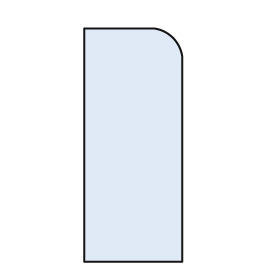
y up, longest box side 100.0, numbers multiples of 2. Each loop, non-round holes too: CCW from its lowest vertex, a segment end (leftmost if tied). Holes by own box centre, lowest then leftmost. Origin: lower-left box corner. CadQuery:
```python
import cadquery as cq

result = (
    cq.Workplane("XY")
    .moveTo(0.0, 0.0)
    .lineTo(42.0, 0.0)
    .lineTo(42.0, 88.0)
    .threePointArc((38.0, 96.0), (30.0, 100.0))
    .lineTo(0.0, 100.0)
    .close()
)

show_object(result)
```